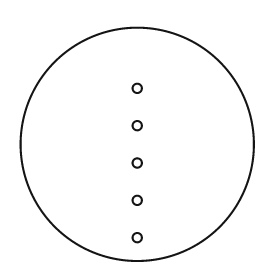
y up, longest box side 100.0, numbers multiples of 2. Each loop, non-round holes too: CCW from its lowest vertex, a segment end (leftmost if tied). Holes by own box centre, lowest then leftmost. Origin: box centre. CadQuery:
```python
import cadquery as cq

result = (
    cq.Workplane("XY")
    .moveTo(0.0, 0.0)
    .circle(50.0)
    .moveTo(0.0, -40.0)
    .circle(2.0)
    .moveTo(0.0, -24.0)
    .circle(2.0)
    .moveTo(0.0, -8.0)
    .circle(2.0)
    .moveTo(0.0, 8.0)
    .circle(2.0)
    .moveTo(0.0, 24.0)
    .circle(2.0)
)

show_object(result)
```